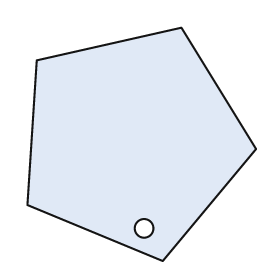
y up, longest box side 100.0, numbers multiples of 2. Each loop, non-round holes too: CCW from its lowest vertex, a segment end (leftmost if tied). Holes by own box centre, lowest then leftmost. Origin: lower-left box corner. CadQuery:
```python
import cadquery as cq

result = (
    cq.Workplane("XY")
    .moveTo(58.0, 0.0)
    .lineTo(98.0, 48.0)
    .lineTo(66.0, 100.0)
    .lineTo(4.0, 86.0)
    .lineTo(0.0, 24.0)
    .close()
    .moveTo(50.0, 14.0)
    .circle(4.0)
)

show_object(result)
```